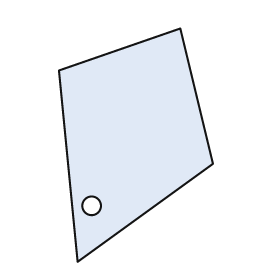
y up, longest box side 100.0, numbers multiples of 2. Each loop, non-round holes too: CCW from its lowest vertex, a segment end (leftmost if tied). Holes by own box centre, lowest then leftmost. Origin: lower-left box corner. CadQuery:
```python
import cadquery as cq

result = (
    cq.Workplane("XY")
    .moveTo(8.0, 0.0)
    .lineTo(66.0, 42.0)
    .lineTo(52.0, 100.0)
    .lineTo(0.0, 82.0)
    .close()
    .moveTo(14.0, 24.0)
    .circle(4.0)
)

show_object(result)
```